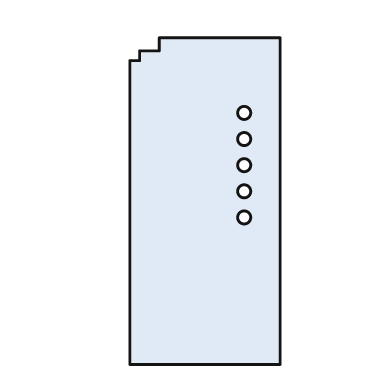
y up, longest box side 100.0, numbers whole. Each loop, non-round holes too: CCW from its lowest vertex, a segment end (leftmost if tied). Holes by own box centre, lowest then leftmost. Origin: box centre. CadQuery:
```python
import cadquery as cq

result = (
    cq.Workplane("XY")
    .moveTo(-23.0, -50.0)
    .lineTo(23.0, -50.0)
    .lineTo(23.0, 50.0)
    .lineTo(-14.0, 50.0)
    .lineTo(-14.0, 46.0)
    .lineTo(-20.0, 46.0)
    .lineTo(-20.0, 43.0)
    .lineTo(-23.0, 43.0)
    .close()
    .moveTo(12.0, -5.0)
    .circle(2.0)
    .moveTo(12.0, 3.0)
    .circle(2.0)
    .moveTo(12.0, 11.0)
    .circle(2.0)
    .moveTo(12.0, 19.0)
    .circle(2.0)
    .moveTo(12.0, 27.0)
    .circle(2.0)
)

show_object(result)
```